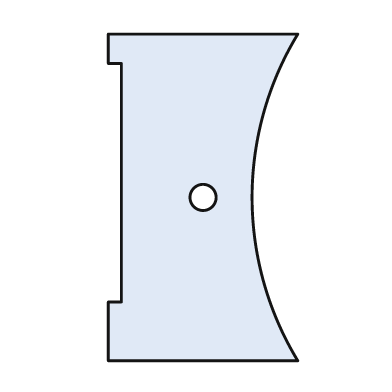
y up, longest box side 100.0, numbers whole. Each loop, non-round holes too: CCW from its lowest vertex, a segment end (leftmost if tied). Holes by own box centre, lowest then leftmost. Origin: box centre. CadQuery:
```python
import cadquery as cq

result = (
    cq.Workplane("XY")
    .moveTo(-29.0, -50.0)
    .lineTo(29.0, -50.0)
    .threePointArc((15.0, 0.0), (29.0, 50.0))
    .lineTo(-29.0, 50.0)
    .lineTo(-29.0, 41.0)
    .lineTo(-25.0, 41.0)
    .lineTo(-25.0, -32.0)
    .lineTo(-29.0, -32.0)
    .close()
    .moveTo(0.0, 0.0)
    .circle(4.0)
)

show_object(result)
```